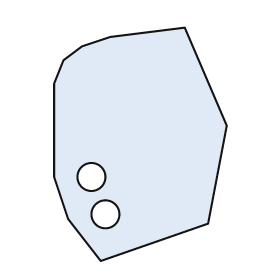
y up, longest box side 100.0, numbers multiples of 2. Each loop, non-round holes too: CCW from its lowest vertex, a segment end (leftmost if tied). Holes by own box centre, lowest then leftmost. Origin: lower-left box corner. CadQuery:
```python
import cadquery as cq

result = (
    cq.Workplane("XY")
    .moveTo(20.0, 0.0)
    .lineTo(66.0, 16.0)
    .lineTo(74.0, 58.0)
    .lineTo(56.0, 100.0)
    .lineTo(24.0, 96.0)
    .lineTo(12.0, 92.0)
    .lineTo(4.0, 86.0)
    .lineTo(0.0, 76.0)
    .lineTo(0.0, 36.0)
    .lineTo(6.0, 18.0)
    .close()
    .moveTo(22.0, 20.0)
    .circle(6.0)
    .moveTo(16.0, 36.0)
    .circle(6.0)
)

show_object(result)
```